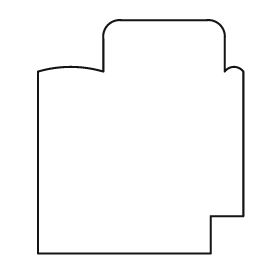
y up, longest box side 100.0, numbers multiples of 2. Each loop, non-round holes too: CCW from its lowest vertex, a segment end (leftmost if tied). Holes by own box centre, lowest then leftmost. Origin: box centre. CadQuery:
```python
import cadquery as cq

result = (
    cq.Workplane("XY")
    .moveTo(-44.0, -50.0)
    .lineTo(30.0, -50.0)
    .lineTo(30.0, -34.0)
    .lineTo(44.0, -34.0)
    .lineTo(44.0, 28.0)
    .threePointArc((40.0, 30.0), (36.0, 28.0))
    .lineTo(36.0, 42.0)
    .threePointArc((34.0, 48.0), (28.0, 50.0))
    .lineTo(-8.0, 50.0)
    .threePointArc((-14.0, 48.0), (-16.0, 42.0))
    .lineTo(-16.0, 28.0)
    .threePointArc((-30.0, 30.0), (-44.0, 28.0))
    .close()
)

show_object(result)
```